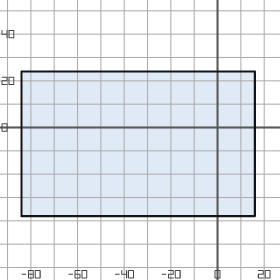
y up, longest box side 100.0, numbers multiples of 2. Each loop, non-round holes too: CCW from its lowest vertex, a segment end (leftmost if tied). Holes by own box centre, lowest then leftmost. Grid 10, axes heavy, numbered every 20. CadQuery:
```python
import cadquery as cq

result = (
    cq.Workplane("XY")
    .moveTo(-84.0, -38.0)
    .lineTo(16.0, -38.0)
    .lineTo(16.0, 24.0)
    .lineTo(-84.0, 24.0)
    .close()
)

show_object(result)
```